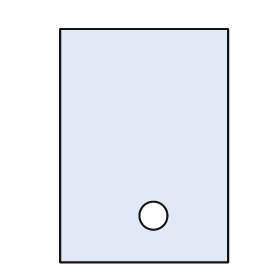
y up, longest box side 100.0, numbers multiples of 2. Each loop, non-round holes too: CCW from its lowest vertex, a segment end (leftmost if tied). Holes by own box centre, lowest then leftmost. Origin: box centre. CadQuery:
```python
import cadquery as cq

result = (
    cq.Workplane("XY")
    .moveTo(-36.0, -50.0)
    .lineTo(36.0, -50.0)
    .lineTo(36.0, 50.0)
    .lineTo(-36.0, 50.0)
    .close()
    .moveTo(4.0, -30.0)
    .circle(6.0)
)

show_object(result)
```